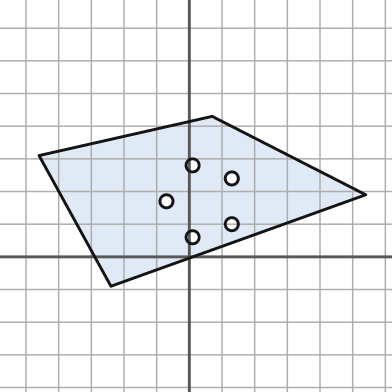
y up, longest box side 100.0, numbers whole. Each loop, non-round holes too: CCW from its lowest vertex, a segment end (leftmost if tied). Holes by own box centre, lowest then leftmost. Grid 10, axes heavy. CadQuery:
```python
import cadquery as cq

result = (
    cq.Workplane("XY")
    .moveTo(-24.0, -9.0)
    .lineTo(54.0, 19.0)
    .lineTo(7.0, 43.0)
    .lineTo(-46.0, 31.0)
    .close()
    .moveTo(1.0, 6.0)
    .circle(2.0)
    .moveTo(13.0, 10.0)
    .circle(2.0)
    .moveTo(-7.0, 17.0)
    .circle(2.0)
    .moveTo(13.0, 24.0)
    .circle(2.0)
    .moveTo(1.0, 28.0)
    .circle(2.0)
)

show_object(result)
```